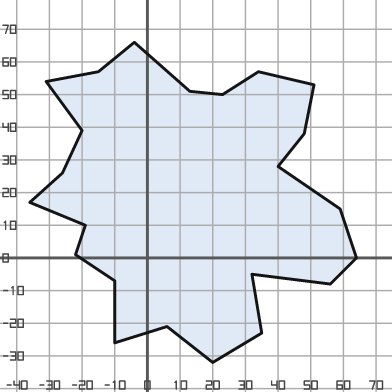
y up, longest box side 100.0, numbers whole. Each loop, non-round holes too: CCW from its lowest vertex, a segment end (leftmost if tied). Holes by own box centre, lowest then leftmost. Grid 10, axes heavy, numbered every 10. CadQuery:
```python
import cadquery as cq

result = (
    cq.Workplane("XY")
    .moveTo(20.0, -32.0)
    .lineTo(35.0, -23.0)
    .lineTo(32.0, -5.0)
    .lineTo(56.0, -8.0)
    .lineTo(64.0, 0.0)
    .lineTo(59.0, 15.0)
    .lineTo(40.0, 28.0)
    .lineTo(48.0, 38.0)
    .lineTo(51.0, 53.0)
    .lineTo(34.0, 57.0)
    .lineTo(23.0, 50.0)
    .lineTo(13.0, 51.0)
    .lineTo(-4.0, 66.0)
    .lineTo(-15.0, 57.0)
    .lineTo(-31.0, 54.0)
    .lineTo(-20.0, 39.0)
    .lineTo(-26.0, 26.0)
    .lineTo(-36.0, 17.0)
    .lineTo(-19.0, 10.0)
    .lineTo(-22.0, 1.0)
    .lineTo(-10.0, -7.0)
    .lineTo(-10.0, -26.0)
    .lineTo(6.0, -21.0)
    .close()
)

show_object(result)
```